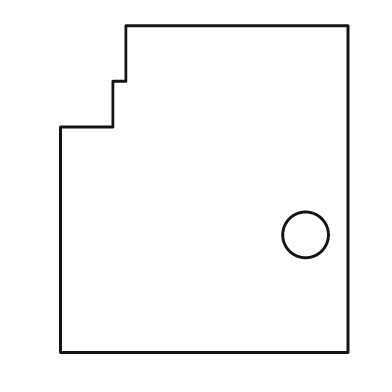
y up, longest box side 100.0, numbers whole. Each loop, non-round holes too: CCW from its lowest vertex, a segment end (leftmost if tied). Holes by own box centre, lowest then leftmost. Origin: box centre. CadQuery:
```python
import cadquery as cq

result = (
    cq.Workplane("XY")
    .moveTo(-44.0, -50.0)
    .lineTo(44.0, -50.0)
    .lineTo(44.0, 50.0)
    .lineTo(-24.0, 50.0)
    .lineTo(-24.0, 33.0)
    .lineTo(-28.0, 33.0)
    .lineTo(-28.0, 19.0)
    .lineTo(-44.0, 19.0)
    .close()
    .moveTo(31.0, -14.0)
    .circle(7.0)
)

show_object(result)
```